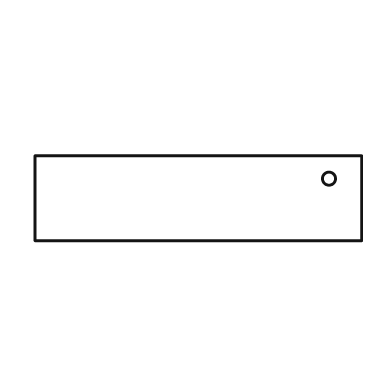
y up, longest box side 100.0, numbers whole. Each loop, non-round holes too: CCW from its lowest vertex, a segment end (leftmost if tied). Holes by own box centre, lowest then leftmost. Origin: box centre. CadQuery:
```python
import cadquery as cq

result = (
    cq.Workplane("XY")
    .moveTo(-50.0, -13.0)
    .lineTo(50.0, -13.0)
    .lineTo(50.0, 13.0)
    .lineTo(-50.0, 13.0)
    .close()
    .moveTo(40.0, 6.0)
    .circle(2.0)
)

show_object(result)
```